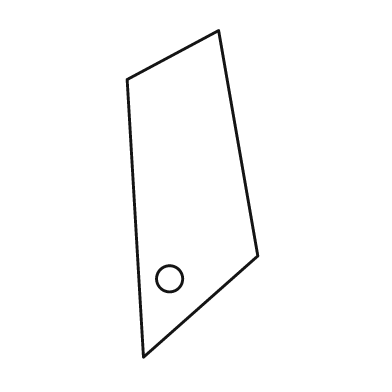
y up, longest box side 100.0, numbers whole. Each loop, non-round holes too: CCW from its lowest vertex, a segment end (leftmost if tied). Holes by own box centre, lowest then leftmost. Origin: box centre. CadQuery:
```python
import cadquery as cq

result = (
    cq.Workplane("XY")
    .moveTo(-15.0, -50.0)
    .lineTo(20.0, -19.0)
    .lineTo(8.0, 50.0)
    .lineTo(-20.0, 35.0)
    .close()
    .moveTo(-7.0, -26.0)
    .circle(4.0)
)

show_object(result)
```